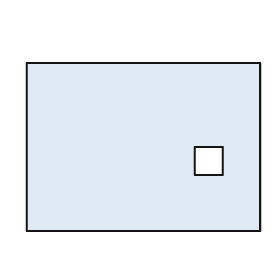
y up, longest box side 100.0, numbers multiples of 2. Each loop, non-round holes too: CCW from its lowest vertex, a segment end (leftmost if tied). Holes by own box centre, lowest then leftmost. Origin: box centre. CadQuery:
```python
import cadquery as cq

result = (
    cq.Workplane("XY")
    .moveTo(-50.0, -36.0)
    .lineTo(50.0, -36.0)
    .lineTo(50.0, 36.0)
    .lineTo(-50.0, 36.0)
    .close()
    .moveTo(22.0, -12.0)
    .lineTo(34.0, -12.0)
    .lineTo(34.0, 0.0)
    .lineTo(22.0, 0.0)
    .close()
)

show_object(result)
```